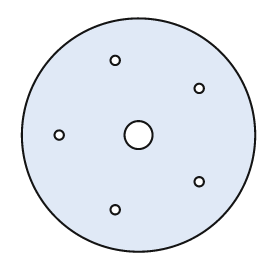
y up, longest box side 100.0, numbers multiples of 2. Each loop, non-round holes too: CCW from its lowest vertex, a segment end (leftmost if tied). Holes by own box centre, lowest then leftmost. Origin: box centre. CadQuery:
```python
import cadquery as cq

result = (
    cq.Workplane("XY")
    .moveTo(0.0, 0.0)
    .circle(50.0)
    .moveTo(-10.0, -32.0)
    .circle(2.0)
    .moveTo(26.0, -20.0)
    .circle(2.0)
    .moveTo(-34.0, 0.0)
    .circle(2.0)
    .moveTo(0.0, 0.0)
    .circle(6.0)
    .moveTo(26.0, 20.0)
    .circle(2.0)
    .moveTo(-10.0, 32.0)
    .circle(2.0)
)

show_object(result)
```